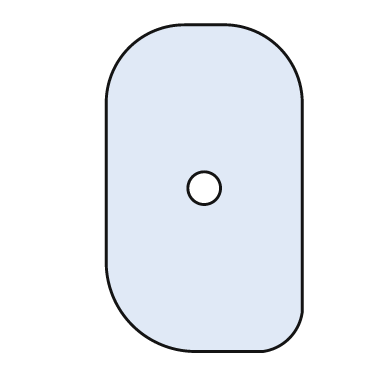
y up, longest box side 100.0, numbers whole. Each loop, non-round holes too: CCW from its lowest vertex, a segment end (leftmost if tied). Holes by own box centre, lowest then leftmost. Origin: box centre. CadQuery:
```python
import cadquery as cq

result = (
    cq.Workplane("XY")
    .moveTo(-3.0, -50.0)
    .lineTo(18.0, -50.0)
    .threePointArc((26.0, -46.0), (30.0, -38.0))
    .lineTo(30.0, 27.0)
    .threePointArc((23.0, 43.0), (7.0, 50.0))
    .lineTo(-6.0, 50.0)
    .threePointArc((-23.0, 43.0), (-30.0, 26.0))
    .lineTo(-30.0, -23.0)
    .threePointArc((-22.0, -42.0), (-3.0, -50.0))
    .close()
    .moveTo(0.0, 0.0)
    .circle(5.0)
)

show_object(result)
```